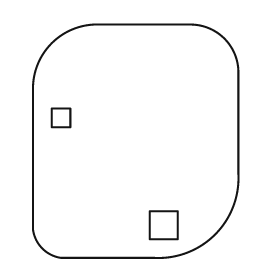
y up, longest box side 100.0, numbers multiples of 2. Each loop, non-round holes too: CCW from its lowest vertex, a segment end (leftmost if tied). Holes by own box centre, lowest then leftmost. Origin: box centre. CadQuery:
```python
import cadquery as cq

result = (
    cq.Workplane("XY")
    .moveTo(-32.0, -50.0)
    .lineTo(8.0, -50.0)
    .threePointArc((34.0, -40.0), (44.0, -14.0))
    .lineTo(44.0, 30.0)
    .threePointArc((38.0, 44.0), (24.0, 50.0))
    .lineTo(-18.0, 50.0)
    .threePointArc((-36.0, 42.0), (-44.0, 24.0))
    .lineTo(-44.0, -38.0)
    .threePointArc((-40.0, -46.0), (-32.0, -50.0))
    .close()
    .moveTo(6.0, -42.0)
    .lineTo(18.0, -42.0)
    .lineTo(18.0, -30.0)
    .lineTo(6.0, -30.0)
    .close()
    .moveTo(-36.0, 6.0)
    .lineTo(-28.0, 6.0)
    .lineTo(-28.0, 14.0)
    .lineTo(-36.0, 14.0)
    .close()
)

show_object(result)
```